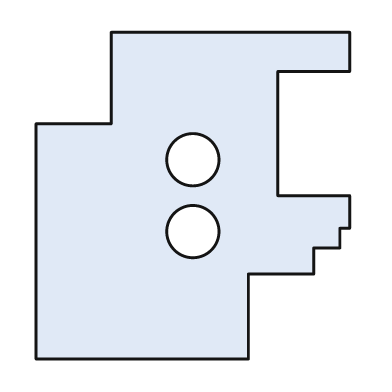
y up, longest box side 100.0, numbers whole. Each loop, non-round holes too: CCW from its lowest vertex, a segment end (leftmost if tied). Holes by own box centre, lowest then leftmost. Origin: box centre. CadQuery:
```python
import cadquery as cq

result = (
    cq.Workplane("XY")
    .moveTo(-48.0, -50.0)
    .lineTo(17.0, -50.0)
    .lineTo(17.0, -24.0)
    .lineTo(37.0, -24.0)
    .lineTo(37.0, -16.0)
    .lineTo(45.0, -16.0)
    .lineTo(45.0, -10.0)
    .lineTo(48.0, -10.0)
    .lineTo(48.0, 0.0)
    .lineTo(26.0, 0.0)
    .lineTo(26.0, 38.0)
    .lineTo(48.0, 38.0)
    .lineTo(48.0, 50.0)
    .lineTo(-25.0, 50.0)
    .lineTo(-25.0, 22.0)
    .lineTo(-48.0, 22.0)
    .close()
    .moveTo(0.0, -11.0)
    .circle(8.0)
    .moveTo(0.0, 11.0)
    .circle(8.0)
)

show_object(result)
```